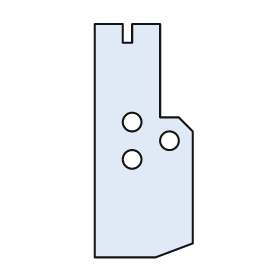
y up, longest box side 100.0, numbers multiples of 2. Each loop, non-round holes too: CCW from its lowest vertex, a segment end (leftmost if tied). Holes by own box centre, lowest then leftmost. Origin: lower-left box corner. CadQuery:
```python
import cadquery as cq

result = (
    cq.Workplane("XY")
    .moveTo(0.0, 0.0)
    .lineTo(26.0, 0.0)
    .lineTo(42.0, 6.0)
    .lineTo(42.0, 54.0)
    .lineTo(36.0, 60.0)
    .lineTo(28.0, 60.0)
    .lineTo(28.0, 100.0)
    .lineTo(16.0, 100.0)
    .lineTo(16.0, 92.0)
    .lineTo(12.0, 92.0)
    .lineTo(12.0, 100.0)
    .lineTo(0.0, 100.0)
    .close()
    .moveTo(16.0, 42.0)
    .circle(4.0)
    .moveTo(32.0, 50.0)
    .circle(4.0)
    .moveTo(16.0, 58.0)
    .circle(4.0)
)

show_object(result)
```